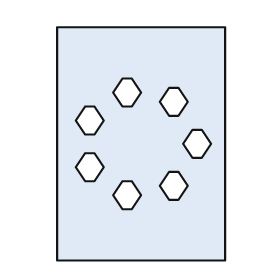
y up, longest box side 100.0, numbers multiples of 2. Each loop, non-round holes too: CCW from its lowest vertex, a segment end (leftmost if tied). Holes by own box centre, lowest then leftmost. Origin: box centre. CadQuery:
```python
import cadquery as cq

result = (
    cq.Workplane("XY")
    .moveTo(-36.0, -50.0)
    .lineTo(36.0, -50.0)
    .lineTo(36.0, 50.0)
    .lineTo(-36.0, 50.0)
    .close()
    .moveTo(-8.0, -28.0)
    .lineTo(-4.0, -28.0)
    .lineTo(0.0, -22.0)
    .lineTo(-4.0, -16.0)
    .lineTo(-8.0, -16.0)
    .lineTo(-12.0, -22.0)
    .close()
    .moveTo(12.0, -24.0)
    .lineTo(16.0, -24.0)
    .lineTo(20.0, -18.0)
    .lineTo(16.0, -12.0)
    .lineTo(12.0, -12.0)
    .lineTo(8.0, -18.0)
    .close()
    .moveTo(-24.0, -16.0)
    .lineTo(-20.0, -16.0)
    .lineTo(-16.0, -10.0)
    .lineTo(-20.0, -4.0)
    .lineTo(-24.0, -4.0)
    .lineTo(-28.0, -10.0)
    .close()
    .moveTo(22.0, -6.0)
    .lineTo(26.0, -6.0)
    .lineTo(30.0, 0.0)
    .lineTo(26.0, 6.0)
    .lineTo(22.0, 6.0)
    .lineTo(18.0, 0.0)
    .close()
    .moveTo(-24.0, 4.0)
    .lineTo(-20.0, 4.0)
    .lineTo(-16.0, 10.0)
    .lineTo(-20.0, 16.0)
    .lineTo(-24.0, 16.0)
    .lineTo(-28.0, 10.0)
    .close()
    .moveTo(12.0, 12.0)
    .lineTo(16.0, 12.0)
    .lineTo(20.0, 18.0)
    .lineTo(16.0, 24.0)
    .lineTo(12.0, 24.0)
    .lineTo(8.0, 18.0)
    .close()
    .moveTo(-8.0, 16.0)
    .lineTo(-4.0, 16.0)
    .lineTo(0.0, 22.0)
    .lineTo(-4.0, 28.0)
    .lineTo(-8.0, 28.0)
    .lineTo(-12.0, 22.0)
    .close()
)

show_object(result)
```